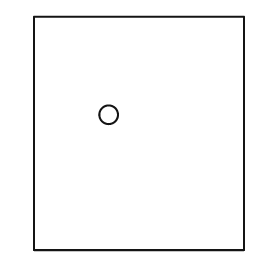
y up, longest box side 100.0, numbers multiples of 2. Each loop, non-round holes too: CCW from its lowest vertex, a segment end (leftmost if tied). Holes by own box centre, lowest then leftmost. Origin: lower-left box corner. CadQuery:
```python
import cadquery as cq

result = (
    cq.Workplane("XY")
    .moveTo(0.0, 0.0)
    .lineTo(90.0, 0.0)
    .lineTo(90.0, 100.0)
    .lineTo(0.0, 100.0)
    .close()
    .moveTo(32.0, 58.0)
    .circle(4.0)
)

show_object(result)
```